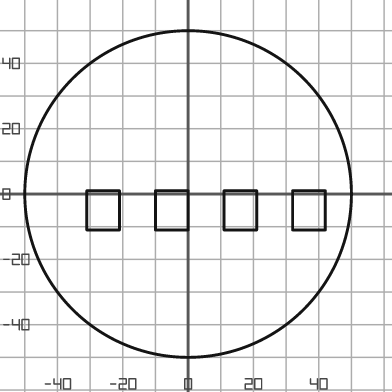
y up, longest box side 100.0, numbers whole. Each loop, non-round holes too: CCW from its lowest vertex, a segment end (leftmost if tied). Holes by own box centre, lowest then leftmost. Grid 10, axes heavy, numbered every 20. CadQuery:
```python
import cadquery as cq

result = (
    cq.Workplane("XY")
    .moveTo(0.0, 0.0)
    .circle(50.0)
    .moveTo(-31.0, -11.0)
    .lineTo(-21.0, -11.0)
    .lineTo(-21.0, 1.0)
    .lineTo(-31.0, 1.0)
    .close()
    .moveTo(-10.0, -11.0)
    .lineTo(0.0, -11.0)
    .lineTo(0.0, 1.0)
    .lineTo(-10.0, 1.0)
    .close()
    .moveTo(11.0, -11.0)
    .lineTo(21.0, -11.0)
    .lineTo(21.0, 1.0)
    .lineTo(11.0, 1.0)
    .close()
    .moveTo(32.0, -11.0)
    .lineTo(42.0, -11.0)
    .lineTo(42.0, 1.0)
    .lineTo(32.0, 1.0)
    .close()
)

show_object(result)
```